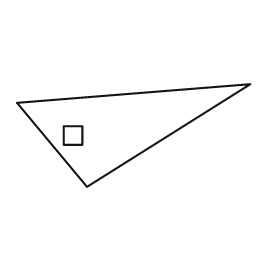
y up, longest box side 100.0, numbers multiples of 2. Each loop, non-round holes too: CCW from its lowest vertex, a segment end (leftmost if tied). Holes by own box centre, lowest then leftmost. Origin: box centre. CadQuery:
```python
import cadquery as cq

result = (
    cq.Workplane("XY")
    .moveTo(-20.0, -22.0)
    .lineTo(50.0, 22.0)
    .lineTo(-50.0, 14.0)
    .close()
    .moveTo(-30.0, -4.0)
    .lineTo(-22.0, -4.0)
    .lineTo(-22.0, 4.0)
    .lineTo(-30.0, 4.0)
    .close()
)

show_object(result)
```